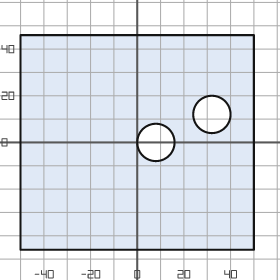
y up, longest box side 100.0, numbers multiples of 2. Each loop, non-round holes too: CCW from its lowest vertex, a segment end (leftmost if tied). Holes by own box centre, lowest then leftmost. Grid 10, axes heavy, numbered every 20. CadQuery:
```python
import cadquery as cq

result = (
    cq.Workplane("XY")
    .moveTo(-50.0, -46.0)
    .lineTo(50.0, -46.0)
    .lineTo(50.0, 46.0)
    .lineTo(-50.0, 46.0)
    .close()
    .moveTo(8.0, 0.0)
    .circle(8.0)
    .moveTo(32.0, 12.0)
    .circle(8.0)
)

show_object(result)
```